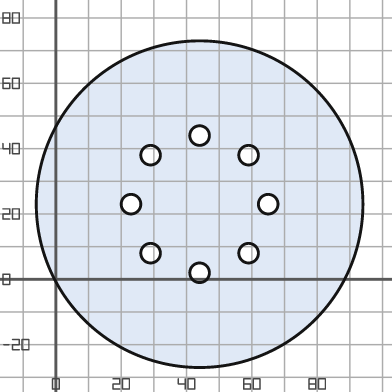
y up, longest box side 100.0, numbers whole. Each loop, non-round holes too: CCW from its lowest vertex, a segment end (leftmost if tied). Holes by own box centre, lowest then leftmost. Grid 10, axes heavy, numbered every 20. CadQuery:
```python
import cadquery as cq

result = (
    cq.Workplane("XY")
    .moveTo(44.0, 23.0)
    .circle(50.0)
    .moveTo(44.0, 2.0)
    .circle(3.0)
    .moveTo(29.0, 8.0)
    .circle(3.0)
    .moveTo(59.0, 8.0)
    .circle(3.0)
    .moveTo(23.0, 23.0)
    .circle(3.0)
    .moveTo(65.0, 23.0)
    .circle(3.0)
    .moveTo(29.0, 38.0)
    .circle(3.0)
    .moveTo(59.0, 38.0)
    .circle(3.0)
    .moveTo(44.0, 44.0)
    .circle(3.0)
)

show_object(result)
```